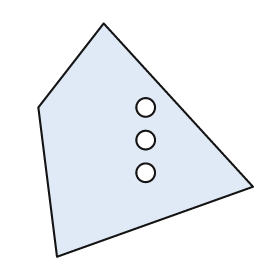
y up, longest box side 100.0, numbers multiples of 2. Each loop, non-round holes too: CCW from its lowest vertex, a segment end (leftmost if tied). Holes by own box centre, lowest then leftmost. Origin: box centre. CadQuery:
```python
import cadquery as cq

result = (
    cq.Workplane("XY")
    .moveTo(-38.0, -50.0)
    .lineTo(46.0, -20.0)
    .lineTo(-18.0, 50.0)
    .lineTo(-46.0, 14.0)
    .close()
    .moveTo(0.0, -14.0)
    .circle(4.0)
    .moveTo(0.0, 0.0)
    .circle(4.0)
    .moveTo(0.0, 14.0)
    .circle(4.0)
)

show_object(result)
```